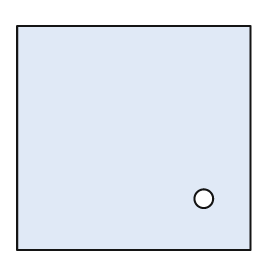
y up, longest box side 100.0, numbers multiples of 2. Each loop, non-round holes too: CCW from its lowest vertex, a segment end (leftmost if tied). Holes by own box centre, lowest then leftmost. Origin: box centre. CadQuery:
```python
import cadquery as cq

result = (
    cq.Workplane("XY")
    .moveTo(-50.0, -48.0)
    .lineTo(50.0, -48.0)
    .lineTo(50.0, 48.0)
    .lineTo(-50.0, 48.0)
    .close()
    .moveTo(30.0, -26.0)
    .circle(4.0)
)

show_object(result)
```